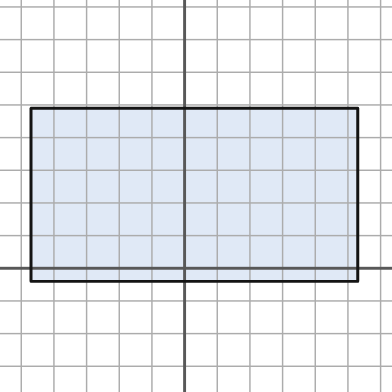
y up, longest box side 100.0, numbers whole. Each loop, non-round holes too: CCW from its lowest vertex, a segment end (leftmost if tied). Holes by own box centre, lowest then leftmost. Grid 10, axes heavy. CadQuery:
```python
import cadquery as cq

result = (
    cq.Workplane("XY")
    .moveTo(-47.0, -4.0)
    .lineTo(53.0, -4.0)
    .lineTo(53.0, 49.0)
    .lineTo(-47.0, 49.0)
    .close()
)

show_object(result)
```